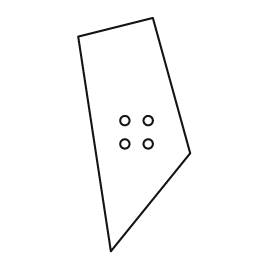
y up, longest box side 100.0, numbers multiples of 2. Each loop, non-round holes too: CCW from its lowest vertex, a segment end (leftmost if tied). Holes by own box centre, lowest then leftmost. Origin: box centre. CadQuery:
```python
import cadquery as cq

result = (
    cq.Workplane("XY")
    .moveTo(-10.0, -50.0)
    .lineTo(24.0, -8.0)
    .lineTo(8.0, 50.0)
    .lineTo(-24.0, 42.0)
    .close()
    .moveTo(-4.0, -4.0)
    .circle(2.0)
    .moveTo(6.0, -4.0)
    .circle(2.0)
    .moveTo(-4.0, 6.0)
    .circle(2.0)
    .moveTo(6.0, 6.0)
    .circle(2.0)
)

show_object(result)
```